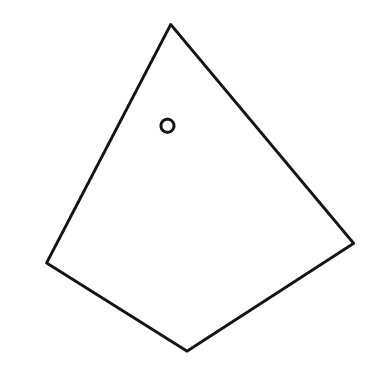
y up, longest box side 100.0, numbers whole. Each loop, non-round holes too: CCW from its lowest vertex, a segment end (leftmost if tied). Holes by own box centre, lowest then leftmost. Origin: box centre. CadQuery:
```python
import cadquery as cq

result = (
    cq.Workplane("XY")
    .moveTo(-4.0, -50.0)
    .lineTo(47.0, -17.0)
    .lineTo(-9.0, 50.0)
    .lineTo(-47.0, -23.0)
    .close()
    .moveTo(-10.0, 19.0)
    .circle(2.0)
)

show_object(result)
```